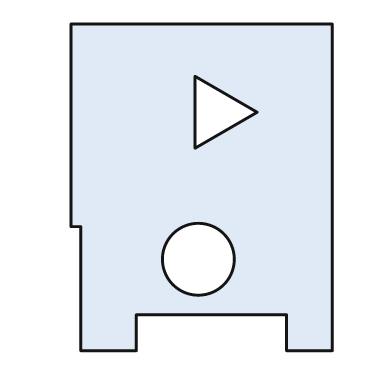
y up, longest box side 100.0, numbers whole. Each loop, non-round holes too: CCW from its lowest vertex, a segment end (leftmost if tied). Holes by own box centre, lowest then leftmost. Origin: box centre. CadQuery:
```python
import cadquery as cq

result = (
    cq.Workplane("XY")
    .moveTo(-37.0, -50.0)
    .lineTo(-20.0, -50.0)
    .lineTo(-20.0, -39.0)
    .lineTo(26.0, -39.0)
    .lineTo(26.0, -50.0)
    .lineTo(40.0, -50.0)
    .lineTo(40.0, 50.0)
    .lineTo(-40.0, 50.0)
    .lineTo(-40.0, -12.0)
    .lineTo(-37.0, -12.0)
    .close()
    .moveTo(-1.0, -22.0)
    .circle(11.0)
    .moveTo(-2.0, 12.0)
    .lineTo(17.0, 23.0)
    .lineTo(-2.0, 34.0)
    .close()
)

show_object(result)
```